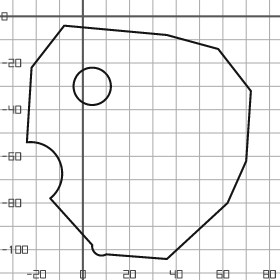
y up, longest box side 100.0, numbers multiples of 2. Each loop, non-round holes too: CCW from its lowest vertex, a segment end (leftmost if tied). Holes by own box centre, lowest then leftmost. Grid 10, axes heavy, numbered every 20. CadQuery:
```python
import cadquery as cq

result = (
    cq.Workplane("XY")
    .moveTo(36.0, -104.0)
    .lineTo(62.0, -80.0)
    .lineTo(70.0, -62.0)
    .lineTo(72.0, -32.0)
    .lineTo(58.0, -14.0)
    .lineTo(36.0, -8.0)
    .lineTo(-8.0, -4.0)
    .lineTo(-22.0, -22.0)
    .lineTo(-24.0, -54.0)
    .threePointArc((-10.0, -62.0), (-14.0, -78.0))
    .lineTo(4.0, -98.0)
    .threePointArc((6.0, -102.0), (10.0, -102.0))
    .close()
    .moveTo(4.0, -30.0)
    .circle(8.0)
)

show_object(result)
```